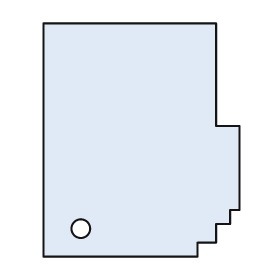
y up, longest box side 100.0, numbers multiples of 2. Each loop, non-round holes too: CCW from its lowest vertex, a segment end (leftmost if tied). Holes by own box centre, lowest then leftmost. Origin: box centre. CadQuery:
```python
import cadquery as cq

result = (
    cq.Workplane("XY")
    .moveTo(-42.0, -50.0)
    .lineTo(24.0, -50.0)
    .lineTo(24.0, -44.0)
    .lineTo(32.0, -44.0)
    .lineTo(32.0, -36.0)
    .lineTo(38.0, -36.0)
    .lineTo(38.0, -30.0)
    .lineTo(42.0, -30.0)
    .lineTo(42.0, 6.0)
    .lineTo(32.0, 6.0)
    .lineTo(32.0, 50.0)
    .lineTo(-42.0, 50.0)
    .close()
    .moveTo(-26.0, -38.0)
    .circle(4.0)
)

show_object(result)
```